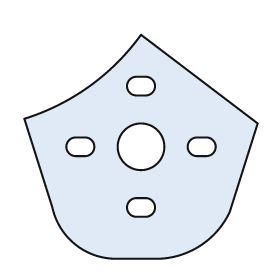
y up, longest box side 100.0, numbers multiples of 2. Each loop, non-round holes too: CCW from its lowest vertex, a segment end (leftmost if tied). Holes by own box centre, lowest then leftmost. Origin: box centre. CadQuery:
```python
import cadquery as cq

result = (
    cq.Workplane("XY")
    .moveTo(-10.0, -48.0)
    .lineTo(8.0, -48.0)
    .threePointArc((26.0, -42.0), (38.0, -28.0))
    .lineTo(50.0, 10.0)
    .lineTo(0.0, 48.0)
    .threePointArc((-22.0, 26.0), (-50.0, 12.0))
    .lineTo(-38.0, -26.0)
    .threePointArc((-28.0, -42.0), (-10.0, -48.0))
    .close()
    .moveTo(-2.0, -30.0)
    .lineTo(2.0, -30.0)
    .threePointArc((6.0, -26.0), (2.0, -22.0))
    .lineTo(-2.0, -22.0)
    .threePointArc((-6.0, -26.0), (-2.0, -30.0))
    .close()
    .moveTo(-28.0, -4.0)
    .lineTo(-24.0, -4.0)
    .threePointArc((-20.0, 0.0), (-24.0, 4.0))
    .lineTo(-28.0, 4.0)
    .threePointArc((-32.0, 0.0), (-28.0, -4.0))
    .close()
    .moveTo(0.0, 0.0)
    .circle(10.0)
    .moveTo(24.0, -4.0)
    .lineTo(28.0, -4.0)
    .threePointArc((32.0, 0.0), (28.0, 4.0))
    .lineTo(24.0, 4.0)
    .threePointArc((20.0, 0.0), (24.0, -4.0))
    .close()
    .moveTo(-2.0, 22.0)
    .lineTo(2.0, 22.0)
    .threePointArc((6.0, 26.0), (2.0, 30.0))
    .lineTo(-2.0, 30.0)
    .threePointArc((-6.0, 26.0), (-2.0, 22.0))
    .close()
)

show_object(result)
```